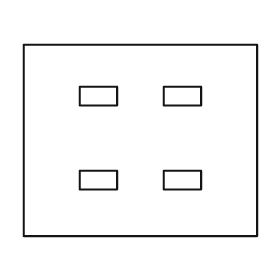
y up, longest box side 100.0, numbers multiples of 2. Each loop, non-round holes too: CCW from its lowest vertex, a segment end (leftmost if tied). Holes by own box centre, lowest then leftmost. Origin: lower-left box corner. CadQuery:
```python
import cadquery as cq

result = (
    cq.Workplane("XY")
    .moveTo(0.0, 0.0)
    .lineTo(100.0, 0.0)
    .lineTo(100.0, 82.0)
    .lineTo(0.0, 82.0)
    .close()
    .moveTo(24.0, 20.0)
    .lineTo(40.0, 20.0)
    .lineTo(40.0, 28.0)
    .lineTo(24.0, 28.0)
    .close()
    .moveTo(60.0, 20.0)
    .lineTo(76.0, 20.0)
    .lineTo(76.0, 28.0)
    .lineTo(60.0, 28.0)
    .close()
    .moveTo(24.0, 56.0)
    .lineTo(40.0, 56.0)
    .lineTo(40.0, 64.0)
    .lineTo(24.0, 64.0)
    .close()
    .moveTo(60.0, 56.0)
    .lineTo(76.0, 56.0)
    .lineTo(76.0, 64.0)
    .lineTo(60.0, 64.0)
    .close()
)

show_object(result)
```